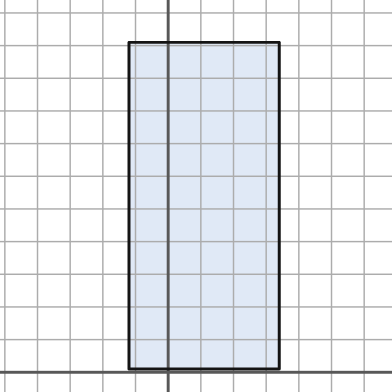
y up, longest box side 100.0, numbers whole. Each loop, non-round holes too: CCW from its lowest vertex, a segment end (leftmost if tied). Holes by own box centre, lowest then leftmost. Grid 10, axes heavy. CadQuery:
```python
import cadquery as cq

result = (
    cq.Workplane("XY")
    .moveTo(-12.0, 1.0)
    .lineTo(34.0, 1.0)
    .lineTo(34.0, 101.0)
    .lineTo(-12.0, 101.0)
    .close()
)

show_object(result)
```